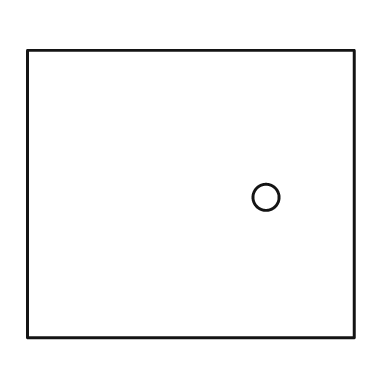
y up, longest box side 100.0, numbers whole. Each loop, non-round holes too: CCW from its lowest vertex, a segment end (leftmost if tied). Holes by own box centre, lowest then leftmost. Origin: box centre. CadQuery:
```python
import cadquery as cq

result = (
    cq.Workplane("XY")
    .moveTo(-50.0, -44.0)
    .lineTo(50.0, -44.0)
    .lineTo(50.0, 44.0)
    .lineTo(-50.0, 44.0)
    .close()
    .moveTo(23.0, -1.0)
    .circle(4.0)
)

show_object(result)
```